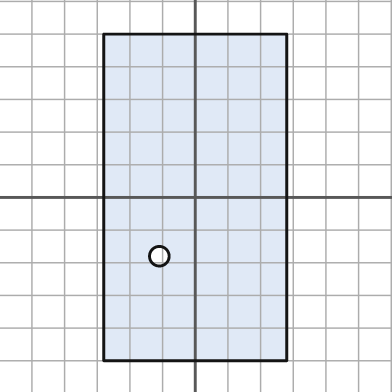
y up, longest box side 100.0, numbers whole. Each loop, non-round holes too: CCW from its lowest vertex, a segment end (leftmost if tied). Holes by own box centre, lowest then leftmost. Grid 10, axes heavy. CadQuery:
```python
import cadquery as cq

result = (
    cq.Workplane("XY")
    .moveTo(-28.0, -50.0)
    .lineTo(28.0, -50.0)
    .lineTo(28.0, 50.0)
    .lineTo(-28.0, 50.0)
    .close()
    .moveTo(-11.0, -18.0)
    .circle(3.0)
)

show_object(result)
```